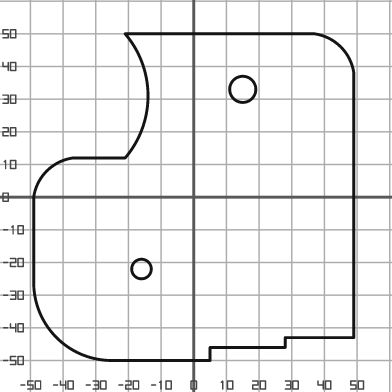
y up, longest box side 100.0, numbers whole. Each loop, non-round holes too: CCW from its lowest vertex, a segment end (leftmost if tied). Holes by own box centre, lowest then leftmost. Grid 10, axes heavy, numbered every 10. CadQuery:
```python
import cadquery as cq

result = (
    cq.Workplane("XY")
    .moveTo(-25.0, -50.0)
    .lineTo(5.0, -50.0)
    .lineTo(5.0, -46.0)
    .lineTo(28.0, -46.0)
    .lineTo(28.0, -43.0)
    .lineTo(49.0, -43.0)
    .lineTo(49.0, 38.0)
    .threePointArc((45.0, 46.0), (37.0, 50.0))
    .lineTo(-21.0, 50.0)
    .threePointArc((-14.0, 31.0), (-21.0, 12.0))
    .lineTo(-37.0, 12.0)
    .threePointArc((-45.0, 8.0), (-49.0, 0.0))
    .lineTo(-49.0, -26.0)
    .threePointArc((-42.0, -43.0), (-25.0, -50.0))
    .close()
    .moveTo(-16.0, -22.0)
    .circle(3.0)
    .moveTo(15.0, 33.0)
    .circle(4.0)
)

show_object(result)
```